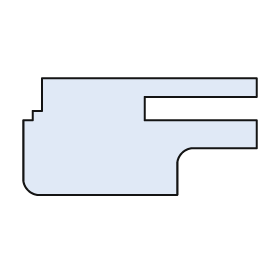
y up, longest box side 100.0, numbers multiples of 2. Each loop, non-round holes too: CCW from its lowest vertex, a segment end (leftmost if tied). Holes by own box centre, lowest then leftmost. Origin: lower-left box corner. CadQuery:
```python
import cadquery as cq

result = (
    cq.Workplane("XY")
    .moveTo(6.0, 0.0)
    .lineTo(66.0, 0.0)
    .lineTo(66.0, 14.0)
    .threePointArc((68.0, 18.0), (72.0, 20.0))
    .lineTo(100.0, 20.0)
    .lineTo(100.0, 32.0)
    .lineTo(52.0, 32.0)
    .lineTo(52.0, 42.0)
    .lineTo(100.0, 42.0)
    .lineTo(100.0, 50.0)
    .lineTo(8.0, 50.0)
    .lineTo(8.0, 36.0)
    .lineTo(4.0, 36.0)
    .lineTo(4.0, 32.0)
    .lineTo(0.0, 32.0)
    .lineTo(0.0, 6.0)
    .threePointArc((2.0, 2.0), (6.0, 0.0))
    .close()
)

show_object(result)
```